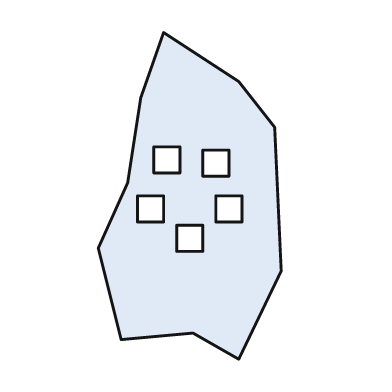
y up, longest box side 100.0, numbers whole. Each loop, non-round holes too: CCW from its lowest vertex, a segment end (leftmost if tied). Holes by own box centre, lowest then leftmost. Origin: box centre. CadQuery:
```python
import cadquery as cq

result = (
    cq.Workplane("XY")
    .moveTo(15.0, -50.0)
    .lineTo(28.0, -23.0)
    .lineTo(26.0, 21.0)
    .lineTo(15.0, 35.0)
    .lineTo(-8.0, 50.0)
    .lineTo(-15.0, 30.0)
    .lineTo(-19.0, 4.0)
    .lineTo(-28.0, -16.0)
    .lineTo(-21.0, -44.0)
    .lineTo(1.0, -42.0)
    .close()
    .moveTo(-4.0, -17.0)
    .lineTo(4.0, -17.0)
    .lineTo(4.0, -9.0)
    .lineTo(-4.0, -9.0)
    .close()
    .moveTo(-16.0, -8.0)
    .lineTo(-8.0, -8.0)
    .lineTo(-8.0, 0.0)
    .lineTo(-16.0, 0.0)
    .close()
    .moveTo(8.0, -8.0)
    .lineTo(16.0, -8.0)
    .lineTo(16.0, 0.0)
    .lineTo(8.0, 0.0)
    .close()
    .moveTo(4.0, 6.0)
    .lineTo(12.0, 6.0)
    .lineTo(12.0, 14.0)
    .lineTo(4.0, 14.0)
    .close()
    .moveTo(-11.0, 7.0)
    .lineTo(-3.0, 7.0)
    .lineTo(-3.0, 15.0)
    .lineTo(-11.0, 15.0)
    .close()
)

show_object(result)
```